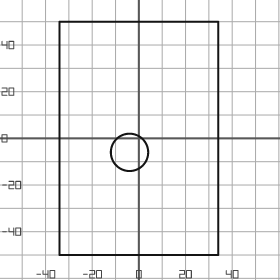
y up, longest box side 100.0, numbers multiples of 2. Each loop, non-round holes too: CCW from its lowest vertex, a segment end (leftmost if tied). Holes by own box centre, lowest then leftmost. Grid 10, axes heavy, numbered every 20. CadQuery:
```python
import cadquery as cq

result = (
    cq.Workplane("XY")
    .moveTo(-34.0, -50.0)
    .lineTo(34.0, -50.0)
    .lineTo(34.0, 50.0)
    .lineTo(-34.0, 50.0)
    .close()
    .moveTo(-4.0, -6.0)
    .circle(8.0)
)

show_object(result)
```